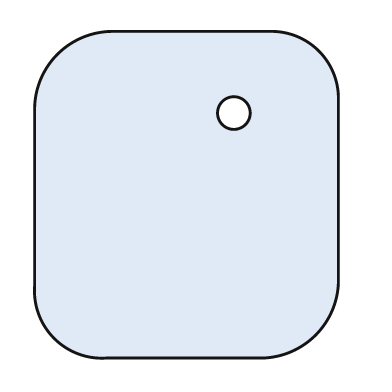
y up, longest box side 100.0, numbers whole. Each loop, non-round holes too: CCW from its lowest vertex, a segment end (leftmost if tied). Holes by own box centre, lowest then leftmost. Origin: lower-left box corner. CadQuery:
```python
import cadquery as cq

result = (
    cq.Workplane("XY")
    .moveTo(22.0, 0.0)
    .lineTo(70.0, 0.0)
    .threePointArc((86.0, 7.0), (93.0, 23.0))
    .lineTo(93.0, 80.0)
    .threePointArc((87.0, 94.0), (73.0, 100.0))
    .lineTo(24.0, 100.0)
    .threePointArc((7.0, 93.0), (0.0, 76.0))
    .lineTo(0.0, 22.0)
    .threePointArc((6.0, 6.0), (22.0, 0.0))
    .close()
    .moveTo(61.0, 75.0)
    .circle(5.0)
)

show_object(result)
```